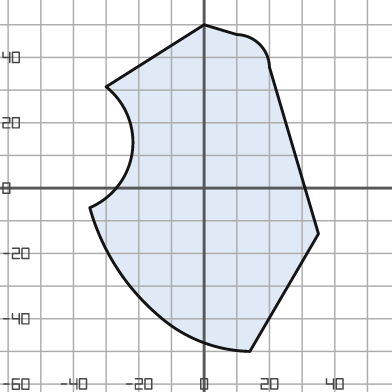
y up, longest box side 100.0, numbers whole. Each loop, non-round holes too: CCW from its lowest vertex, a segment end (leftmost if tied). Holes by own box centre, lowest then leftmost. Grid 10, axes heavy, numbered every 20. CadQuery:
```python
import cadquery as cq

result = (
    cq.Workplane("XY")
    .moveTo(14.0, -50.0)
    .lineTo(35.0, -14.0)
    .lineTo(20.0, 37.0)
    .threePointArc((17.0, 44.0), (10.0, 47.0))
    .lineTo(0.0, 50.0)
    .lineTo(-30.0, 31.0)
    .threePointArc((-22.0, 11.0), (-35.0, -6.0))
    .threePointArc((-27.0, -24.0), (-14.0, -39.0))
    .threePointArc((-1.0, -47.0), (14.0, -50.0))
    .close()
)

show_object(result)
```